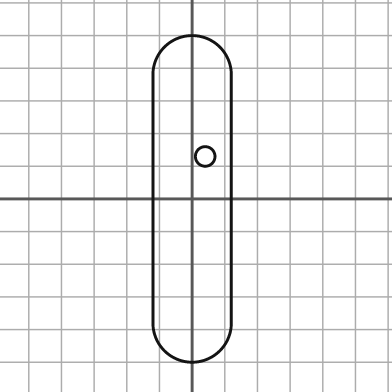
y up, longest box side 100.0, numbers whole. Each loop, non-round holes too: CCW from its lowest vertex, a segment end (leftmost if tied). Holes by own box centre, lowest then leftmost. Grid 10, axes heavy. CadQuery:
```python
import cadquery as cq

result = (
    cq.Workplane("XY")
    .moveTo(-12.0, -38.0)
    .threePointArc((0.0, -50.0), (12.0, -38.0))
    .lineTo(12.0, 38.0)
    .threePointArc((0.0, 50.0), (-12.0, 38.0))
    .close()
    .moveTo(4.0, 13.0)
    .circle(3.0)
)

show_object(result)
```